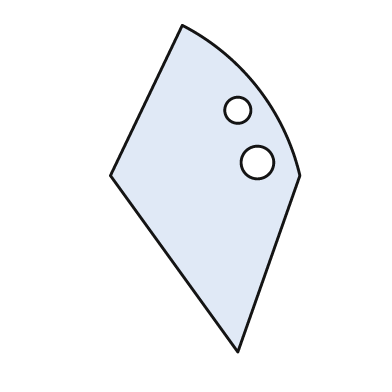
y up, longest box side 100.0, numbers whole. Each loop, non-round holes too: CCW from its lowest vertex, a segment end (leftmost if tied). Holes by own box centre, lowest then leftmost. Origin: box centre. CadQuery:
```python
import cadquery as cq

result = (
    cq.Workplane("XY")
    .moveTo(10.0, -50.0)
    .lineTo(29.0, 4.0)
    .threePointArc((16.0, 31.0), (-7.0, 50.0))
    .lineTo(-29.0, 4.0)
    .close()
    .moveTo(16.0, 8.0)
    .circle(5.0)
    .moveTo(10.0, 24.0)
    .circle(4.0)
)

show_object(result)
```